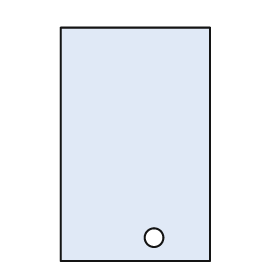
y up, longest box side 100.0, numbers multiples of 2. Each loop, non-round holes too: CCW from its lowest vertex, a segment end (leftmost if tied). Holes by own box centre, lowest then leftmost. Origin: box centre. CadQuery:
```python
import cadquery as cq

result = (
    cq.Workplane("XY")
    .moveTo(-32.0, -50.0)
    .lineTo(32.0, -50.0)
    .lineTo(32.0, 50.0)
    .lineTo(-32.0, 50.0)
    .close()
    .moveTo(8.0, -40.0)
    .circle(4.0)
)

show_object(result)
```